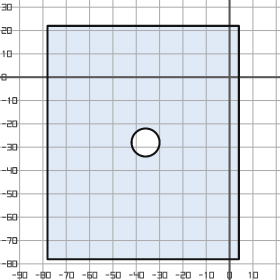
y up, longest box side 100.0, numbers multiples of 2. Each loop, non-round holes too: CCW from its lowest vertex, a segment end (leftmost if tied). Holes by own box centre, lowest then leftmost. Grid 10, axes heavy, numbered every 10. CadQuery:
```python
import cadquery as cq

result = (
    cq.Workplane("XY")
    .moveTo(-78.0, -78.0)
    .lineTo(4.0, -78.0)
    .lineTo(4.0, 22.0)
    .lineTo(-78.0, 22.0)
    .close()
    .moveTo(-36.0, -28.0)
    .circle(6.0)
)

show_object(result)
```